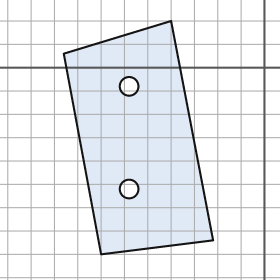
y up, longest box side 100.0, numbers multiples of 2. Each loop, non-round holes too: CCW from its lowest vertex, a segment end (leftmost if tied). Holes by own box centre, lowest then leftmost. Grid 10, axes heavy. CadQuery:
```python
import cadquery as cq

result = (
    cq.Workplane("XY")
    .moveTo(-70.0, -80.0)
    .lineTo(-22.0, -74.0)
    .lineTo(-40.0, 20.0)
    .lineTo(-86.0, 6.0)
    .close()
    .moveTo(-58.0, -52.0)
    .circle(4.0)
    .moveTo(-58.0, -8.0)
    .circle(4.0)
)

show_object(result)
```